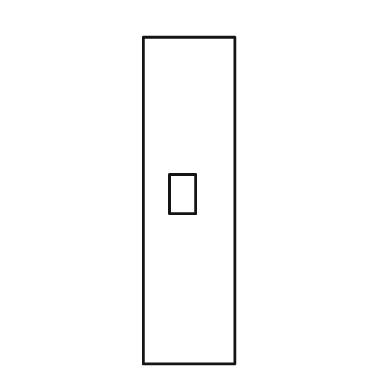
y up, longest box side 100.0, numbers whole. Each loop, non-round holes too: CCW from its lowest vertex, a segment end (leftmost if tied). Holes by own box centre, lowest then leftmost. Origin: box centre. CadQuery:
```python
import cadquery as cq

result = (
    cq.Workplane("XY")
    .moveTo(-14.0, -50.0)
    .lineTo(14.0, -50.0)
    .lineTo(14.0, 50.0)
    .lineTo(-14.0, 50.0)
    .close()
    .moveTo(-6.0, -4.0)
    .lineTo(2.0, -4.0)
    .lineTo(2.0, 8.0)
    .lineTo(-6.0, 8.0)
    .close()
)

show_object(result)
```